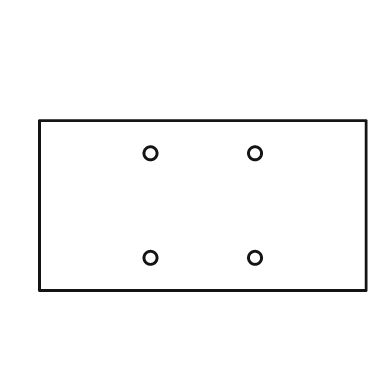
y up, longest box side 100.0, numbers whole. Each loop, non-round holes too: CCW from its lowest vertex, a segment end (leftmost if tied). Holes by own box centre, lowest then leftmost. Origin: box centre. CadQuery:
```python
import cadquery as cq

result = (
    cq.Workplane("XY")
    .moveTo(-50.0, -26.0)
    .lineTo(50.0, -26.0)
    .lineTo(50.0, 26.0)
    .lineTo(-50.0, 26.0)
    .close()
    .moveTo(-16.0, -16.0)
    .circle(2.0)
    .moveTo(16.0, -16.0)
    .circle(2.0)
    .moveTo(-16.0, 16.0)
    .circle(2.0)
    .moveTo(16.0, 16.0)
    .circle(2.0)
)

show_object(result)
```